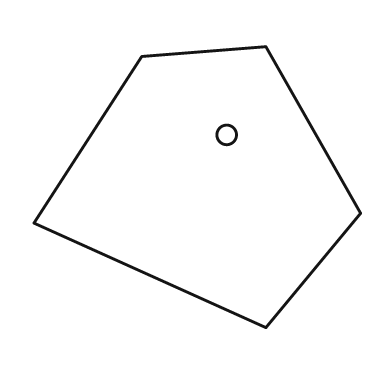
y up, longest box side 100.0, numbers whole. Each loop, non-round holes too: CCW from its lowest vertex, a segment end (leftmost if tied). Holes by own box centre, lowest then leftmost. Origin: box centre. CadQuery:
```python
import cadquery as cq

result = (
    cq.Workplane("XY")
    .moveTo(21.0, -43.0)
    .lineTo(50.0, -8.0)
    .lineTo(21.0, 43.0)
    .lineTo(-17.0, 40.0)
    .lineTo(-50.0, -11.0)
    .close()
    .moveTo(9.0, 16.0)
    .circle(3.0)
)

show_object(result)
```